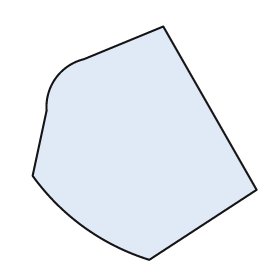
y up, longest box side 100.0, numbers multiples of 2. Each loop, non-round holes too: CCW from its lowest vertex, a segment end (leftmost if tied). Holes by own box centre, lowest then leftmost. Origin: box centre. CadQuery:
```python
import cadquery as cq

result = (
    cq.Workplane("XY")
    .moveTo(2.0, -50.0)
    .lineTo(48.0, -20.0)
    .lineTo(8.0, 50.0)
    .lineTo(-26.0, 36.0)
    .threePointArc((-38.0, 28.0), (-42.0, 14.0))
    .lineTo(-48.0, -14.0)
    .threePointArc((-26.0, -36.0), (2.0, -50.0))
    .close()
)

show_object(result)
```